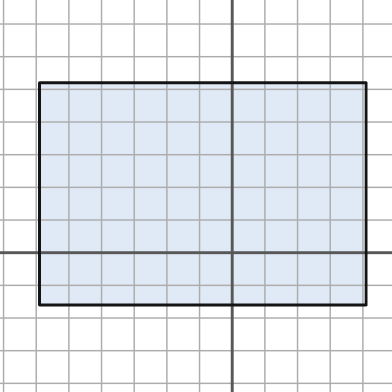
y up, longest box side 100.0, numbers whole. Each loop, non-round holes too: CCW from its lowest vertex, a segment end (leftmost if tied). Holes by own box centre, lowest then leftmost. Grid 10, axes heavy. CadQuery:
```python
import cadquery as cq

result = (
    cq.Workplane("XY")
    .moveTo(-59.0, -16.0)
    .lineTo(41.0, -16.0)
    .lineTo(41.0, 52.0)
    .lineTo(-59.0, 52.0)
    .close()
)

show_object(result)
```